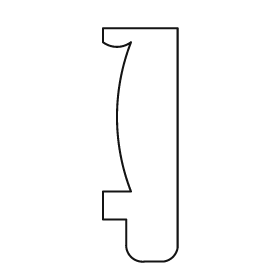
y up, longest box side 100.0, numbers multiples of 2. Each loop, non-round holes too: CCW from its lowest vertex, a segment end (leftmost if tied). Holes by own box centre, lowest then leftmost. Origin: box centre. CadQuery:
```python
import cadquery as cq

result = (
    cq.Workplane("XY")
    .moveTo(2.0, -50.0)
    .lineTo(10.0, -50.0)
    .threePointArc((14.0, -48.0), (16.0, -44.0))
    .lineTo(16.0, 50.0)
    .lineTo(-16.0, 50.0)
    .lineTo(-16.0, 44.0)
    .threePointArc((-10.0, 42.0), (-4.0, 44.0))
    .threePointArc((-10.0, 12.0), (-4.0, -20.0))
    .lineTo(-16.0, -20.0)
    .lineTo(-16.0, -32.0)
    .lineTo(-6.0, -32.0)
    .lineTo(-6.0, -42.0)
    .threePointArc((-4.0, -48.0), (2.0, -50.0))
    .close()
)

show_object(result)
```